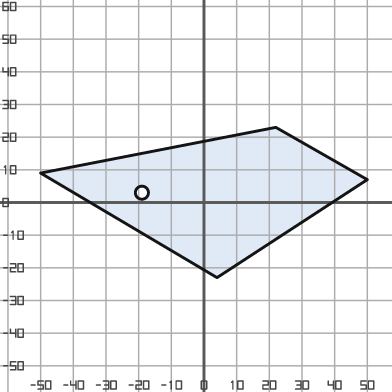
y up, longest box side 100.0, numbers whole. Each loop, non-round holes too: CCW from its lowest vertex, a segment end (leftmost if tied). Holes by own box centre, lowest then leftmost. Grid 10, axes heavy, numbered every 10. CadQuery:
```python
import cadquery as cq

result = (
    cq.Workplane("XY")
    .moveTo(4.0, -23.0)
    .lineTo(50.0, 7.0)
    .lineTo(22.0, 23.0)
    .lineTo(-50.0, 9.0)
    .close()
    .moveTo(-19.0, 3.0)
    .circle(2.0)
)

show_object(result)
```